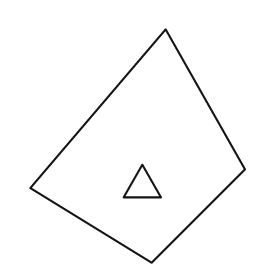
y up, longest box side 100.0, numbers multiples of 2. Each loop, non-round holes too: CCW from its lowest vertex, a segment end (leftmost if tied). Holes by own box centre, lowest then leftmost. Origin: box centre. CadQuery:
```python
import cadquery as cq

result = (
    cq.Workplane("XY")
    .moveTo(6.0, -50.0)
    .lineTo(46.0, -10.0)
    .lineTo(12.0, 50.0)
    .lineTo(-46.0, -18.0)
    .close()
    .moveTo(-6.0, -22.0)
    .lineTo(10.0, -22.0)
    .lineTo(2.0, -8.0)
    .close()
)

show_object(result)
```